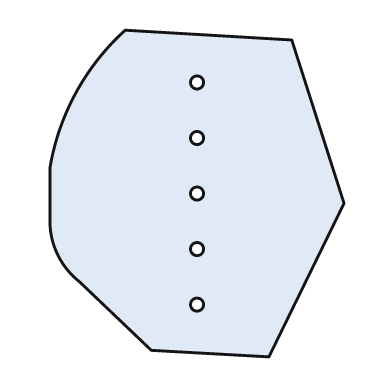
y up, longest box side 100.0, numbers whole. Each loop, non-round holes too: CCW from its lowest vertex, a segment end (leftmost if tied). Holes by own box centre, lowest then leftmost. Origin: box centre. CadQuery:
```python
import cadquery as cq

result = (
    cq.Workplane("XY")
    .moveTo(22.0, -50.0)
    .lineTo(45.0, -3.0)
    .lineTo(29.0, 47.0)
    .lineTo(-22.0, 50.0)
    .threePointArc((-37.0, 31.0), (-45.0, 8.0))
    .lineTo(-45.0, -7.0)
    .threePointArc((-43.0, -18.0), (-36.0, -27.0))
    .lineTo(-14.0, -48.0)
    .close()
    .moveTo(0.0, -34.0)
    .circle(2.0)
    .moveTo(0.0, -17.0)
    .circle(2.0)
    .moveTo(0.0, 0.0)
    .circle(2.0)
    .moveTo(0.0, 17.0)
    .circle(2.0)
    .moveTo(0.0, 34.0)
    .circle(2.0)
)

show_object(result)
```